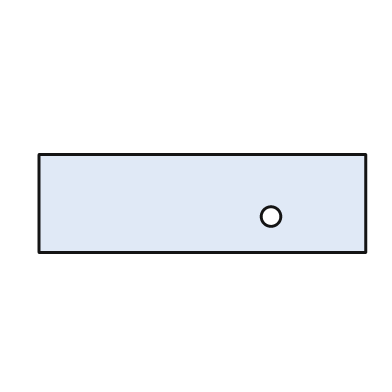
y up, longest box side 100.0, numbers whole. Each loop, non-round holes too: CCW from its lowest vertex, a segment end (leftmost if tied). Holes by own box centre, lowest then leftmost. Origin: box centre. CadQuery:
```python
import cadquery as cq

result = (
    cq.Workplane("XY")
    .moveTo(-50.0, -15.0)
    .lineTo(50.0, -15.0)
    .lineTo(50.0, 15.0)
    .lineTo(-50.0, 15.0)
    .close()
    .moveTo(21.0, -4.0)
    .circle(3.0)
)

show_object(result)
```